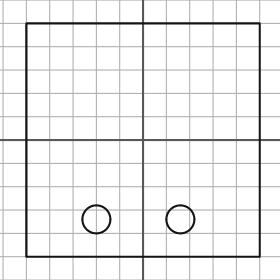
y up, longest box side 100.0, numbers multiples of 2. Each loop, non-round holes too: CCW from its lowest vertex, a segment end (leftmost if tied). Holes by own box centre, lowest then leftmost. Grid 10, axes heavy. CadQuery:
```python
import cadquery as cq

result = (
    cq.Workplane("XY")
    .moveTo(-50.0, -50.0)
    .lineTo(50.0, -50.0)
    .lineTo(50.0, 50.0)
    .lineTo(-50.0, 50.0)
    .close()
    .moveTo(-20.0, -34.0)
    .circle(6.0)
    .moveTo(16.0, -34.0)
    .circle(6.0)
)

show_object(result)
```